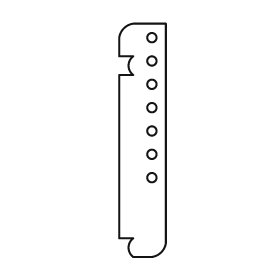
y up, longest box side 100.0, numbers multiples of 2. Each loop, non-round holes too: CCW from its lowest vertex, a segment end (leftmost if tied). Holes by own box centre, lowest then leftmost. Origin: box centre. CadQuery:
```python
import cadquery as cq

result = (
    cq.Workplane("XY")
    .moveTo(-4.0, -50.0)
    .lineTo(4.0, -50.0)
    .threePointArc((8.0, -48.0), (10.0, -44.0))
    .lineTo(10.0, 50.0)
    .lineTo(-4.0, 50.0)
    .threePointArc((-8.0, 48.0), (-10.0, 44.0))
    .lineTo(-10.0, 36.0)
    .lineTo(-4.0, 36.0)
    .threePointArc((-6.0, 32.0), (-4.0, 28.0))
    .lineTo(-10.0, 28.0)
    .lineTo(-10.0, -42.0)
    .lineTo(-4.0, -42.0)
    .threePointArc((-6.0, -46.0), (-4.0, -50.0))
    .close()
    .moveTo(4.0, -16.0)
    .circle(2.0)
    .moveTo(4.0, -6.0)
    .circle(2.0)
    .moveTo(4.0, 4.0)
    .circle(2.0)
    .moveTo(4.0, 14.0)
    .circle(2.0)
    .moveTo(4.0, 24.0)
    .circle(2.0)
    .moveTo(4.0, 34.0)
    .circle(2.0)
    .moveTo(4.0, 44.0)
    .circle(2.0)
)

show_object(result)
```